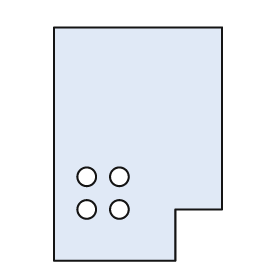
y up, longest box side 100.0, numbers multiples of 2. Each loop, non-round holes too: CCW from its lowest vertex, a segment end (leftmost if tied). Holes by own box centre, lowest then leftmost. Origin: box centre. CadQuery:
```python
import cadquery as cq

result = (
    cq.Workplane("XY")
    .moveTo(-36.0, -50.0)
    .lineTo(16.0, -50.0)
    .lineTo(16.0, -28.0)
    .lineTo(36.0, -28.0)
    .lineTo(36.0, 50.0)
    .lineTo(-36.0, 50.0)
    .close()
    .moveTo(-22.0, -28.0)
    .circle(4.0)
    .moveTo(-8.0, -28.0)
    .circle(4.0)
    .moveTo(-22.0, -14.0)
    .circle(4.0)
    .moveTo(-8.0, -14.0)
    .circle(4.0)
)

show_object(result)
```